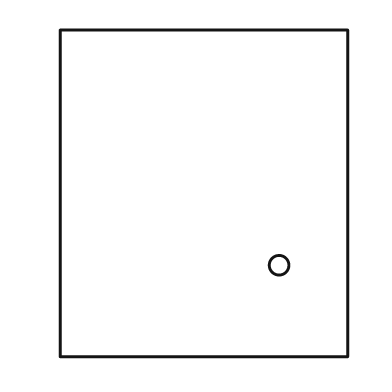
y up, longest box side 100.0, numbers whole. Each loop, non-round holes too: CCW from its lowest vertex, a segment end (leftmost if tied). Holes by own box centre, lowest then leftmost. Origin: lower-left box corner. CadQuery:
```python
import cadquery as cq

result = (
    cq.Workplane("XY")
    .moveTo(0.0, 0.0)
    .lineTo(88.0, 0.0)
    .lineTo(88.0, 100.0)
    .lineTo(0.0, 100.0)
    .close()
    .moveTo(67.0, 28.0)
    .circle(3.0)
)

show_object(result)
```